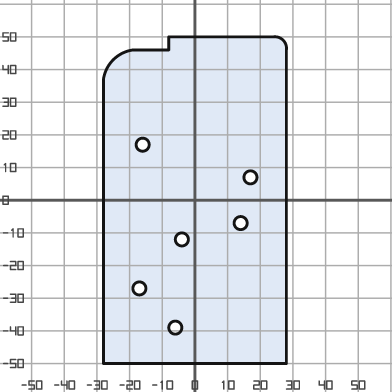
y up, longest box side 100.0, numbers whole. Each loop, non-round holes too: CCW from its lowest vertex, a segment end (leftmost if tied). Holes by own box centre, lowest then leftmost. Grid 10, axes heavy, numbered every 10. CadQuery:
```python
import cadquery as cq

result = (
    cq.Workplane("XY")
    .moveTo(-28.0, -50.0)
    .lineTo(28.0, -50.0)
    .lineTo(28.0, 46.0)
    .threePointArc((27.0, 49.0), (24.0, 50.0))
    .lineTo(-8.0, 50.0)
    .lineTo(-8.0, 46.0)
    .lineTo(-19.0, 46.0)
    .threePointArc((-25.0, 43.0), (-28.0, 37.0))
    .close()
    .moveTo(-6.0, -39.0)
    .circle(2.0)
    .moveTo(-17.0, -27.0)
    .circle(2.0)
    .moveTo(-4.0, -12.0)
    .circle(2.0)
    .moveTo(14.0, -7.0)
    .circle(2.0)
    .moveTo(17.0, 7.0)
    .circle(2.0)
    .moveTo(-16.0, 17.0)
    .circle(2.0)
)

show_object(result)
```